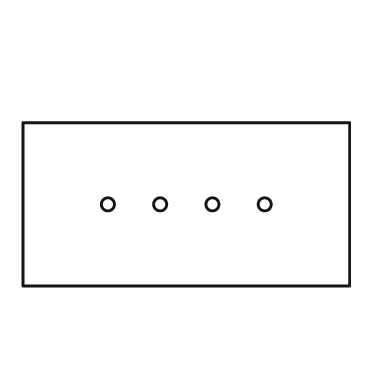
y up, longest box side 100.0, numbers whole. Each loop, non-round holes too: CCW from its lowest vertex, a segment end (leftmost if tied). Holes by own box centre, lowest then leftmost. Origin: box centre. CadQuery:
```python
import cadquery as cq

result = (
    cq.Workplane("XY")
    .moveTo(-50.0, -25.0)
    .lineTo(50.0, -25.0)
    .lineTo(50.0, 25.0)
    .lineTo(-50.0, 25.0)
    .close()
    .moveTo(-24.0, 0.0)
    .circle(2.0)
    .moveTo(-8.0, 0.0)
    .circle(2.0)
    .moveTo(8.0, 0.0)
    .circle(2.0)
    .moveTo(24.0, 0.0)
    .circle(2.0)
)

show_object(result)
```